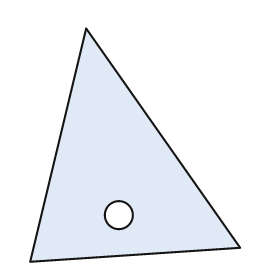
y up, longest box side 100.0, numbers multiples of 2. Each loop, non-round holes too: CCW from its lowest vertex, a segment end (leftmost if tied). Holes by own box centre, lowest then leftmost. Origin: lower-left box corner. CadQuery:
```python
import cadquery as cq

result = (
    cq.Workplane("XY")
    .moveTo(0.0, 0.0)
    .lineTo(90.0, 6.0)
    .lineTo(24.0, 100.0)
    .close()
    .moveTo(38.0, 20.0)
    .circle(6.0)
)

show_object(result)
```